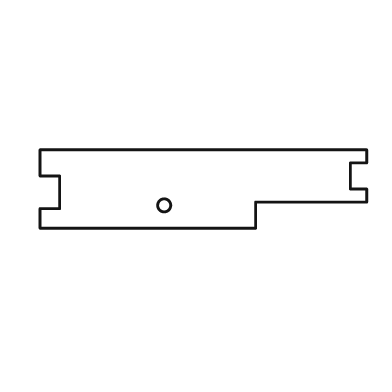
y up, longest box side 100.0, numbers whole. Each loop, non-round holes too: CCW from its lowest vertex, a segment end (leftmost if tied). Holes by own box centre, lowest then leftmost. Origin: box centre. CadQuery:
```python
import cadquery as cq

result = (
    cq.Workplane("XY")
    .moveTo(-50.0, -12.0)
    .lineTo(16.0, -12.0)
    .lineTo(16.0, -4.0)
    .lineTo(50.0, -4.0)
    .lineTo(50.0, 0.0)
    .lineTo(45.0, 0.0)
    .lineTo(45.0, 8.0)
    .lineTo(50.0, 8.0)
    .lineTo(50.0, 12.0)
    .lineTo(-50.0, 12.0)
    .lineTo(-50.0, 4.0)
    .lineTo(-44.0, 4.0)
    .lineTo(-44.0, -6.0)
    .lineTo(-50.0, -6.0)
    .close()
    .moveTo(-12.0, -5.0)
    .circle(2.0)
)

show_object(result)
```